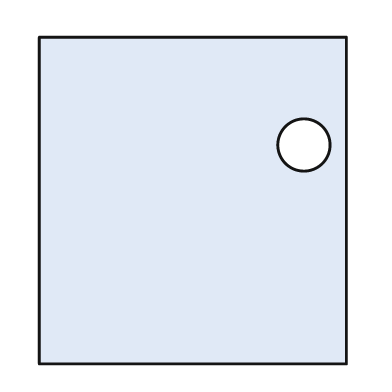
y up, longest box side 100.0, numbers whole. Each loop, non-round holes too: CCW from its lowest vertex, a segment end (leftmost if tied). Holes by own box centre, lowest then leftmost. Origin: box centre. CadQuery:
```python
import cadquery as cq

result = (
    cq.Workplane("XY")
    .moveTo(-47.0, -50.0)
    .lineTo(47.0, -50.0)
    .lineTo(47.0, 50.0)
    .lineTo(-47.0, 50.0)
    .close()
    .moveTo(34.0, 17.0)
    .circle(8.0)
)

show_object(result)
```